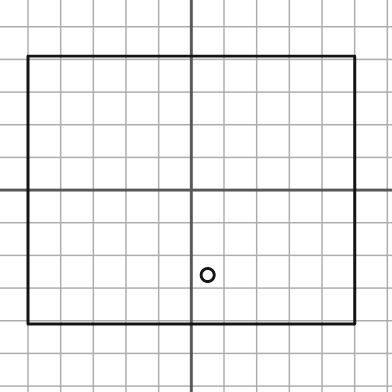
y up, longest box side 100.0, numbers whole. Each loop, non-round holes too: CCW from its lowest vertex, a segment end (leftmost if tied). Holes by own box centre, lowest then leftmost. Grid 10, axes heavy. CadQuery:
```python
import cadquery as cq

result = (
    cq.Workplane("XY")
    .moveTo(-50.0, -41.0)
    .lineTo(50.0, -41.0)
    .lineTo(50.0, 41.0)
    .lineTo(-50.0, 41.0)
    .close()
    .moveTo(5.0, -26.0)
    .circle(2.0)
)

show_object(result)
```